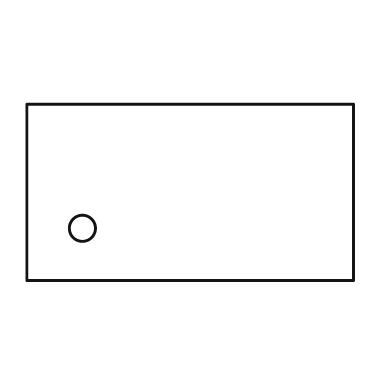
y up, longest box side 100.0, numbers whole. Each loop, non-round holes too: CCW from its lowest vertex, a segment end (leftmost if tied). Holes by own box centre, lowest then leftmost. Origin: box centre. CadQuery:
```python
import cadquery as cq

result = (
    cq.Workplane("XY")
    .moveTo(-50.0, -27.0)
    .lineTo(50.0, -27.0)
    .lineTo(50.0, 27.0)
    .lineTo(-50.0, 27.0)
    .close()
    .moveTo(-33.0, -11.0)
    .circle(4.0)
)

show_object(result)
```